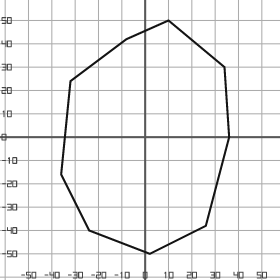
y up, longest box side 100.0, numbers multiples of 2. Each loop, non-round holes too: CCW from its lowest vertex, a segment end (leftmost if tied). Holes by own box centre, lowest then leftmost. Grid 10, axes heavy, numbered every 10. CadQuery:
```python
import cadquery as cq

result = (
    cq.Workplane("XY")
    .moveTo(2.0, -50.0)
    .lineTo(26.0, -38.0)
    .lineTo(36.0, 0.0)
    .lineTo(34.0, 30.0)
    .lineTo(10.0, 50.0)
    .lineTo(-8.0, 42.0)
    .lineTo(-32.0, 24.0)
    .lineTo(-36.0, -16.0)
    .lineTo(-24.0, -40.0)
    .close()
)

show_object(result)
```